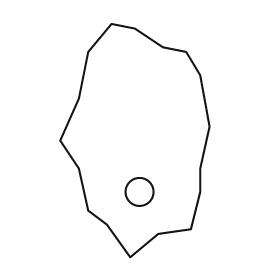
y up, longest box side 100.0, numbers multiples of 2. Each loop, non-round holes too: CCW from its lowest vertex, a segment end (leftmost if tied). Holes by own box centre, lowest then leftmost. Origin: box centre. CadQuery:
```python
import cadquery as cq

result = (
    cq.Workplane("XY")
    .moveTo(-2.0, -50.0)
    .lineTo(10.0, -40.0)
    .lineTo(24.0, -38.0)
    .lineTo(28.0, -22.0)
    .lineTo(28.0, -12.0)
    .lineTo(32.0, 6.0)
    .lineTo(28.0, 28.0)
    .lineTo(22.0, 38.0)
    .lineTo(12.0, 40.0)
    .lineTo(0.0, 48.0)
    .lineTo(-10.0, 50.0)
    .lineTo(-20.0, 38.0)
    .lineTo(-24.0, 18.0)
    .lineTo(-32.0, 0.0)
    .lineTo(-24.0, -12.0)
    .lineTo(-20.0, -30.0)
    .lineTo(-12.0, -36.0)
    .close()
    .moveTo(2.0, -22.0)
    .circle(6.0)
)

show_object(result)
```